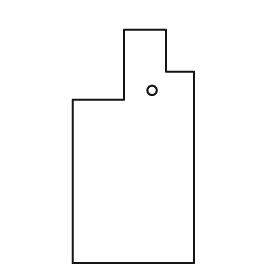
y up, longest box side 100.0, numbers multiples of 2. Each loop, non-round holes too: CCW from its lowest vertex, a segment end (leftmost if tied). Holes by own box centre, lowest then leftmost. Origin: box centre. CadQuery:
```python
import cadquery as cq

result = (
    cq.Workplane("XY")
    .moveTo(-26.0, -50.0)
    .lineTo(26.0, -50.0)
    .lineTo(26.0, 32.0)
    .lineTo(14.0, 32.0)
    .lineTo(14.0, 50.0)
    .lineTo(-4.0, 50.0)
    .lineTo(-4.0, 20.0)
    .lineTo(-26.0, 20.0)
    .close()
    .moveTo(8.0, 24.0)
    .circle(2.0)
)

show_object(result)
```